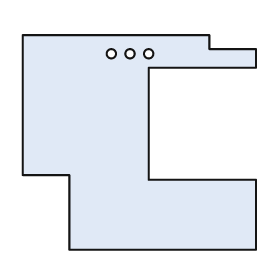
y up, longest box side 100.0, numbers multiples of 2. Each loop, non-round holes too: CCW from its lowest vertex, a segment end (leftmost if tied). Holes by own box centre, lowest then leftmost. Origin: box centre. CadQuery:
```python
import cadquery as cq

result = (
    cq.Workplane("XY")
    .moveTo(-30.0, -46.0)
    .lineTo(50.0, -46.0)
    .lineTo(50.0, -16.0)
    .lineTo(4.0, -16.0)
    .lineTo(4.0, 32.0)
    .lineTo(50.0, 32.0)
    .lineTo(50.0, 40.0)
    .lineTo(30.0, 40.0)
    .lineTo(30.0, 46.0)
    .lineTo(-50.0, 46.0)
    .lineTo(-50.0, -14.0)
    .lineTo(-30.0, -14.0)
    .close()
    .moveTo(-12.0, 38.0)
    .circle(2.0)
    .moveTo(-4.0, 38.0)
    .circle(2.0)
    .moveTo(4.0, 38.0)
    .circle(2.0)
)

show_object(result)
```